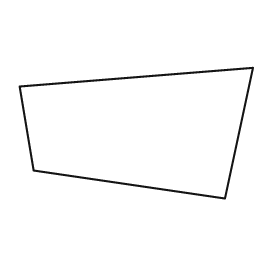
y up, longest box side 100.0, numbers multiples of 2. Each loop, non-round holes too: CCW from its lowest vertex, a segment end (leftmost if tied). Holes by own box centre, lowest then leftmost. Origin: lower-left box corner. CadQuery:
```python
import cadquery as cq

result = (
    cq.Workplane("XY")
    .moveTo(88.0, 0.0)
    .lineTo(100.0, 56.0)
    .lineTo(0.0, 48.0)
    .lineTo(6.0, 12.0)
    .close()
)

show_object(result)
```